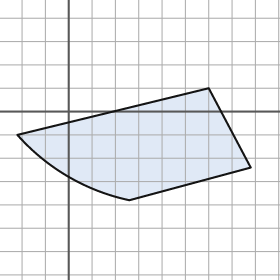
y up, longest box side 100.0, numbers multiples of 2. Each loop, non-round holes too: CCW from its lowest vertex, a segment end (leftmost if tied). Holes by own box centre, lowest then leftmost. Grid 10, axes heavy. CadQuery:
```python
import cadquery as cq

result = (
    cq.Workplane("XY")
    .moveTo(26.0, -38.0)
    .lineTo(78.0, -24.0)
    .lineTo(60.0, 10.0)
    .lineTo(-22.0, -10.0)
    .threePointArc((0.0, -28.0), (26.0, -38.0))
    .close()
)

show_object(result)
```